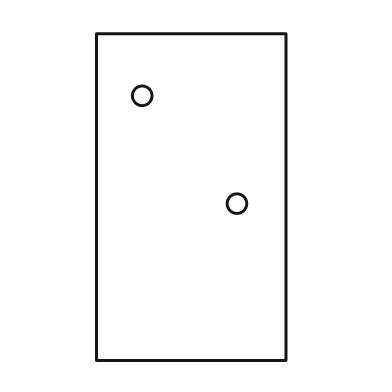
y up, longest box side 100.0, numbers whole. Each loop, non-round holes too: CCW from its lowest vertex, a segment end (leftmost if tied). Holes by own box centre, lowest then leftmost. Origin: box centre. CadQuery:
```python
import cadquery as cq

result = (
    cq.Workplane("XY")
    .moveTo(-29.0, -50.0)
    .lineTo(29.0, -50.0)
    .lineTo(29.0, 50.0)
    .lineTo(-29.0, 50.0)
    .close()
    .moveTo(14.0, -2.0)
    .circle(3.0)
    .moveTo(-15.0, 31.0)
    .circle(3.0)
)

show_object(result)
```